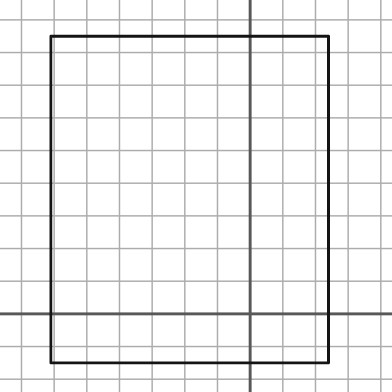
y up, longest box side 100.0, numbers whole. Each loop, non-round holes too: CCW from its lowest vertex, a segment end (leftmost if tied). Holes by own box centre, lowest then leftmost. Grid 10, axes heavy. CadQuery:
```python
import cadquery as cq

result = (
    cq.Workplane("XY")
    .moveTo(-61.0, -15.0)
    .lineTo(24.0, -15.0)
    .lineTo(24.0, 85.0)
    .lineTo(-61.0, 85.0)
    .close()
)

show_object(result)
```